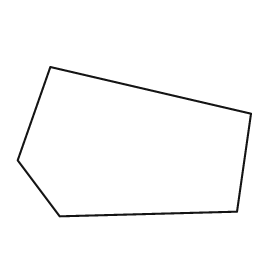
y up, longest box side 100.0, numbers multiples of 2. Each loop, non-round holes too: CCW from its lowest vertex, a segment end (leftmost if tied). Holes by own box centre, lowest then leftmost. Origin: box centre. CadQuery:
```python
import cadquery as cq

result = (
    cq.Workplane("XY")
    .moveTo(-32.0, -32.0)
    .lineTo(44.0, -30.0)
    .lineTo(50.0, 12.0)
    .lineTo(-36.0, 32.0)
    .lineTo(-50.0, -8.0)
    .close()
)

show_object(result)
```